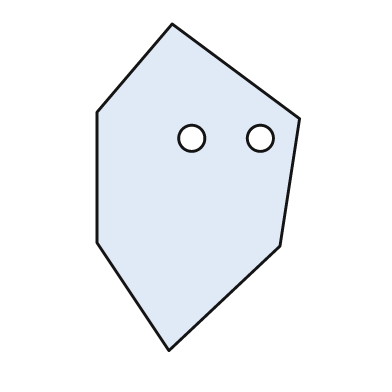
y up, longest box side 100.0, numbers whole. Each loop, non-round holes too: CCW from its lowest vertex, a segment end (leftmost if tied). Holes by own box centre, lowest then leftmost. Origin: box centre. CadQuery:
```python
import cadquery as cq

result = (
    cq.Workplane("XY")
    .moveTo(-9.0, -50.0)
    .lineTo(25.0, -18.0)
    .lineTo(31.0, 21.0)
    .lineTo(-8.0, 50.0)
    .lineTo(-31.0, 23.0)
    .lineTo(-31.0, -17.0)
    .close()
    .moveTo(-2.0, 15.0)
    .circle(4.0)
    .moveTo(19.0, 15.0)
    .circle(4.0)
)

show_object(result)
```